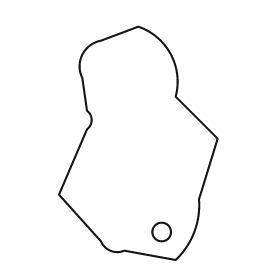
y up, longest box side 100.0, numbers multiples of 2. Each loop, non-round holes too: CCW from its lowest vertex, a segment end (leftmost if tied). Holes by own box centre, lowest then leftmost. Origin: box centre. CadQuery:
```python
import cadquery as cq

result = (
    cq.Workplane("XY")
    .moveTo(16.0, -50.0)
    .threePointArc((24.0, -38.0), (26.0, -24.0))
    .lineTo(34.0, 2.0)
    .lineTo(16.0, 20.0)
    .threePointArc((14.0, 38.0), (0.0, 50.0))
    .lineTo(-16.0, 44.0)
    .threePointArc((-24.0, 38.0), (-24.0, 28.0))
    .lineTo(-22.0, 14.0)
    .threePointArc((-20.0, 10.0), (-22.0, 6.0))
    .lineTo(-34.0, -22.0)
    .lineTo(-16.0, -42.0)
    .threePointArc((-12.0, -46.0), (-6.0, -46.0))
    .close()
    .moveTo(10.0, -38.0)
    .circle(4.0)
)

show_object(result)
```